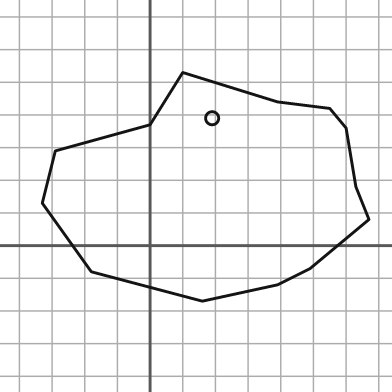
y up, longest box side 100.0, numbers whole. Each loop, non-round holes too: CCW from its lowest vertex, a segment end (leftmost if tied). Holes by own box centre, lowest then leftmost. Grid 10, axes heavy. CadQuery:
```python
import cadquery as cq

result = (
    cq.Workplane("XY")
    .moveTo(16.0, -17.0)
    .lineTo(39.0, -12.0)
    .lineTo(49.0, -7.0)
    .lineTo(67.0, 8.0)
    .lineTo(63.0, 18.0)
    .lineTo(60.0, 36.0)
    .lineTo(55.0, 42.0)
    .lineTo(39.0, 44.0)
    .lineTo(10.0, 53.0)
    .lineTo(0.0, 37.0)
    .lineTo(-29.0, 29.0)
    .lineTo(-33.0, 13.0)
    .lineTo(-18.0, -8.0)
    .close()
    .moveTo(19.0, 39.0)
    .circle(2.0)
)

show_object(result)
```